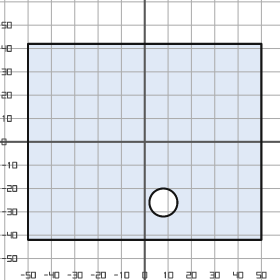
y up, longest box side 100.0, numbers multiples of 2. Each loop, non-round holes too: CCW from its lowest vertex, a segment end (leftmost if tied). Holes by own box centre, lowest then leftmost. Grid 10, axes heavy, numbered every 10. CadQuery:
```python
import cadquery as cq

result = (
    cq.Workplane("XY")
    .moveTo(-50.0, -42.0)
    .lineTo(50.0, -42.0)
    .lineTo(50.0, 42.0)
    .lineTo(-50.0, 42.0)
    .close()
    .moveTo(8.0, -26.0)
    .circle(6.0)
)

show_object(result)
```